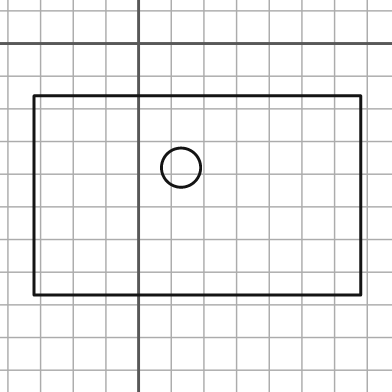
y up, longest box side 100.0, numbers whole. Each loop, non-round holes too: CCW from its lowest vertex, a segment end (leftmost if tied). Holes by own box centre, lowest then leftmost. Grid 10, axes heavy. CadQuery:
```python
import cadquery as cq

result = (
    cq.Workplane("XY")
    .moveTo(-32.0, -77.0)
    .lineTo(68.0, -77.0)
    .lineTo(68.0, -16.0)
    .lineTo(-32.0, -16.0)
    .close()
    .moveTo(13.0, -38.0)
    .circle(6.0)
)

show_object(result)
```